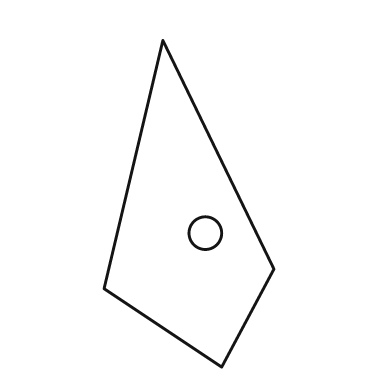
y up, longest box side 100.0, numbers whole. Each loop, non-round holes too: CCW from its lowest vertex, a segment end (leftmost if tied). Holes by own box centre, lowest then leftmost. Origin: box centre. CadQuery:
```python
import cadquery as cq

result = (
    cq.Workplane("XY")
    .moveTo(10.0, -50.0)
    .lineTo(26.0, -20.0)
    .lineTo(-8.0, 50.0)
    .lineTo(-26.0, -26.0)
    .close()
    .moveTo(5.0, -9.0)
    .circle(5.0)
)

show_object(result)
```